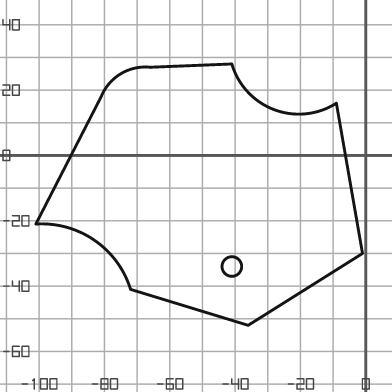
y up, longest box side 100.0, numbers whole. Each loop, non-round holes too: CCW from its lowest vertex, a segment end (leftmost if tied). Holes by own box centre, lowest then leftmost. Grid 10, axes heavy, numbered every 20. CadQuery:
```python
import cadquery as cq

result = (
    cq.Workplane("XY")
    .moveTo(-36.0, -52.0)
    .lineTo(-1.0, -30.0)
    .lineTo(-9.0, 16.0)
    .threePointArc((-28.0, 14.0), (-41.0, 28.0))
    .lineTo(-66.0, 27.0)
    .threePointArc((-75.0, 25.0), (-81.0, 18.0))
    .lineTo(-101.0, -21.0)
    .threePointArc((-83.0, -26.0), (-72.0, -41.0))
    .close()
    .moveTo(-41.0, -34.0)
    .circle(3.0)
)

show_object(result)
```